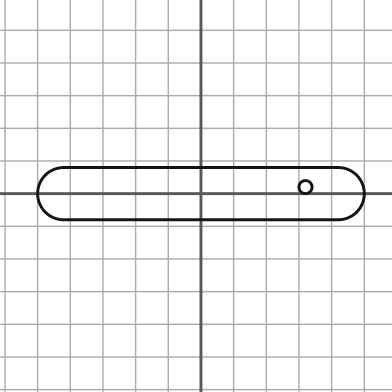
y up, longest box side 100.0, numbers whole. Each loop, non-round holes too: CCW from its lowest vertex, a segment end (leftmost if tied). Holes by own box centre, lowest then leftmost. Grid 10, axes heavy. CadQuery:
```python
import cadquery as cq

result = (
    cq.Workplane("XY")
    .moveTo(-42.0, -8.0)
    .lineTo(42.0, -8.0)
    .threePointArc((50.0, 0.0), (42.0, 8.0))
    .lineTo(-42.0, 8.0)
    .threePointArc((-50.0, 0.0), (-42.0, -8.0))
    .close()
    .moveTo(32.0, 2.0)
    .circle(2.0)
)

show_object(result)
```